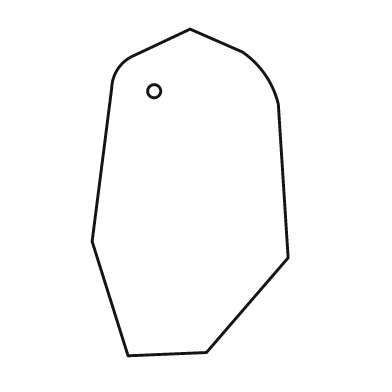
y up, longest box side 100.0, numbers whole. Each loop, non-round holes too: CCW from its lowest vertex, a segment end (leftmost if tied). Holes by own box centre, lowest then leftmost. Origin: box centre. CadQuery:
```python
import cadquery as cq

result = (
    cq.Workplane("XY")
    .moveTo(-19.0, -50.0)
    .lineTo(5.0, -49.0)
    .lineTo(30.0, -20.0)
    .lineTo(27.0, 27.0)
    .threePointArc((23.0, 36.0), (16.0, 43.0))
    .lineTo(0.0, 50.0)
    .lineTo(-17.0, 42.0)
    .threePointArc((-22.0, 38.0), (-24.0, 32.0))
    .lineTo(-30.0, -15.0)
    .close()
    .moveTo(-11.0, 31.0)
    .circle(2.0)
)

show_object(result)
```